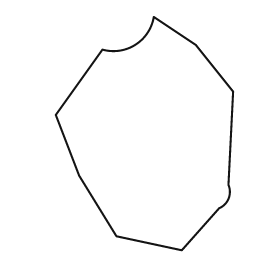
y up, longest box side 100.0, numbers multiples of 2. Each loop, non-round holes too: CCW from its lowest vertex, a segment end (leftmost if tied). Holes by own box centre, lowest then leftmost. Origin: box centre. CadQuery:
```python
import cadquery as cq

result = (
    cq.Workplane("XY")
    .moveTo(16.0, -50.0)
    .lineTo(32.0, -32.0)
    .threePointArc((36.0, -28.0), (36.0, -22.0))
    .lineTo(38.0, 18.0)
    .lineTo(22.0, 38.0)
    .lineTo(4.0, 50.0)
    .threePointArc((-4.0, 38.0), (-18.0, 36.0))
    .lineTo(-38.0, 8.0)
    .lineTo(-28.0, -18.0)
    .lineTo(-12.0, -44.0)
    .close()
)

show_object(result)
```